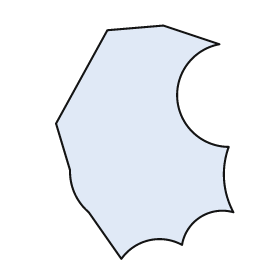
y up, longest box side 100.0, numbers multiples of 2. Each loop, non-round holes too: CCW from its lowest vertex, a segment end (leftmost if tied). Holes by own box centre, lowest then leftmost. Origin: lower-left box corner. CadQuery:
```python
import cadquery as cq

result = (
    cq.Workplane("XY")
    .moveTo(28.0, 0.0)
    .threePointArc((40.0, 8.0), (54.0, 6.0))
    .threePointArc((62.0, 18.0), (76.0, 20.0))
    .threePointArc((72.0, 34.0), (74.0, 48.0))
    .threePointArc((52.0, 68.0), (70.0, 92.0))
    .lineTo(46.0, 100.0)
    .lineTo(22.0, 98.0)
    .lineTo(0.0, 58.0)
    .lineTo(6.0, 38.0)
    .threePointArc((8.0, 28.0), (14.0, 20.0))
    .close()
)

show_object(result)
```